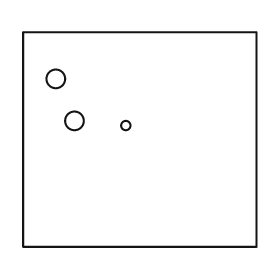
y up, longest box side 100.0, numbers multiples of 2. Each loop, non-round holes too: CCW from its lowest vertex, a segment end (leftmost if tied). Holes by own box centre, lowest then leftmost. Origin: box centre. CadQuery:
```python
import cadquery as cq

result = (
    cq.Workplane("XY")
    .moveTo(-50.0, -46.0)
    .lineTo(50.0, -46.0)
    .lineTo(50.0, 46.0)
    .lineTo(-50.0, 46.0)
    .close()
    .moveTo(-6.0, 6.0)
    .circle(2.0)
    .moveTo(-28.0, 8.0)
    .circle(4.0)
    .moveTo(-36.0, 26.0)
    .circle(4.0)
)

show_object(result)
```